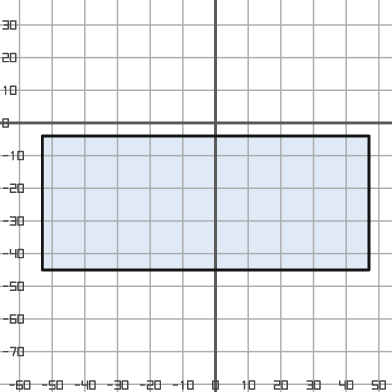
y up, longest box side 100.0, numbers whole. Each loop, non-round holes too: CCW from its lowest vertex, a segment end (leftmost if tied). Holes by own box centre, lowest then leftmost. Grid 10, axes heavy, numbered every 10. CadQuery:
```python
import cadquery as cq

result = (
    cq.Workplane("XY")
    .moveTo(-53.0, -45.0)
    .lineTo(47.0, -45.0)
    .lineTo(47.0, -4.0)
    .lineTo(-53.0, -4.0)
    .close()
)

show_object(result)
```